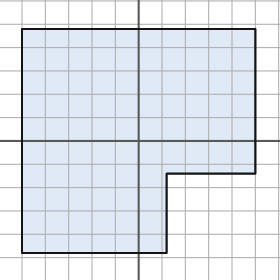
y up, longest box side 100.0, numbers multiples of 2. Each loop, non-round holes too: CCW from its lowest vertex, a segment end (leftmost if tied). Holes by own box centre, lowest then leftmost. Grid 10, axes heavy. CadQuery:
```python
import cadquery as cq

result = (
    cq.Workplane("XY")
    .moveTo(-50.0, -48.0)
    .lineTo(12.0, -48.0)
    .lineTo(12.0, -14.0)
    .lineTo(50.0, -14.0)
    .lineTo(50.0, 48.0)
    .lineTo(-50.0, 48.0)
    .close()
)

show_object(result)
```